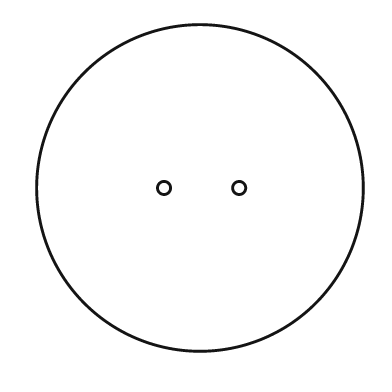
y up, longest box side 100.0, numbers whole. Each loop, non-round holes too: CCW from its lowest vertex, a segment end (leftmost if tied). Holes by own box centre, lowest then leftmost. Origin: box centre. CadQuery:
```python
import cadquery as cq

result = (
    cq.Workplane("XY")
    .moveTo(0.0, 0.0)
    .circle(50.0)
    .moveTo(-11.0, 0.0)
    .circle(2.0)
    .moveTo(12.0, 0.0)
    .circle(2.0)
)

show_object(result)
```